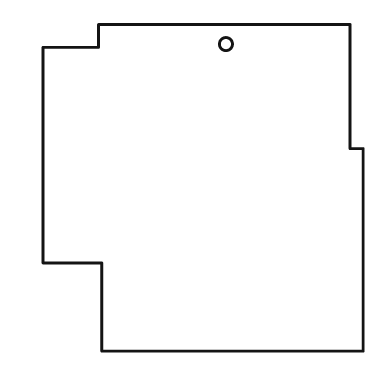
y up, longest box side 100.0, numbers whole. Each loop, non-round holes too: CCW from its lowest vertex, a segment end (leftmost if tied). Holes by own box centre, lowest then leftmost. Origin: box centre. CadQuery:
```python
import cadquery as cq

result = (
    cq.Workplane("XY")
    .moveTo(-31.0, -50.0)
    .lineTo(49.0, -50.0)
    .lineTo(49.0, 12.0)
    .lineTo(45.0, 12.0)
    .lineTo(45.0, 50.0)
    .lineTo(-32.0, 50.0)
    .lineTo(-32.0, 43.0)
    .lineTo(-49.0, 43.0)
    .lineTo(-49.0, -23.0)
    .lineTo(-31.0, -23.0)
    .close()
    .moveTo(7.0, 44.0)
    .circle(2.0)
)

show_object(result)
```